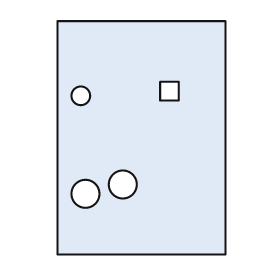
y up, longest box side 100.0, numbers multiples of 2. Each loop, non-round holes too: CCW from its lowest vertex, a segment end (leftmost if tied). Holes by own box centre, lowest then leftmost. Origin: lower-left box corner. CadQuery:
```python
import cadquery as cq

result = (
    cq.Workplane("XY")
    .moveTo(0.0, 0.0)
    .lineTo(72.0, 0.0)
    .lineTo(72.0, 100.0)
    .lineTo(0.0, 100.0)
    .close()
    .moveTo(12.0, 26.0)
    .circle(6.0)
    .moveTo(28.0, 30.0)
    .circle(6.0)
    .moveTo(10.0, 68.0)
    .circle(4.0)
    .moveTo(44.0, 66.0)
    .lineTo(52.0, 66.0)
    .lineTo(52.0, 74.0)
    .lineTo(44.0, 74.0)
    .close()
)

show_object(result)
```